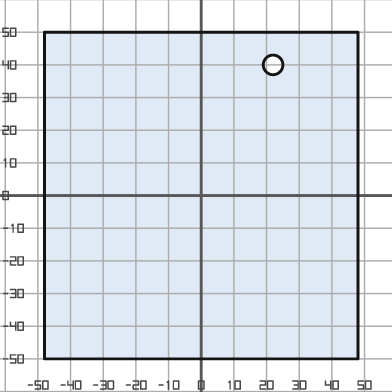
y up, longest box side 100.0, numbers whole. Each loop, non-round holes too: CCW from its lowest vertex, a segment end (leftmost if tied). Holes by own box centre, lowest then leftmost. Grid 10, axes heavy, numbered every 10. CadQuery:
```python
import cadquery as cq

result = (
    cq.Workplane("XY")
    .moveTo(-48.0, -50.0)
    .lineTo(48.0, -50.0)
    .lineTo(48.0, 50.0)
    .lineTo(-48.0, 50.0)
    .close()
    .moveTo(22.0, 40.0)
    .circle(3.0)
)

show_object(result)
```